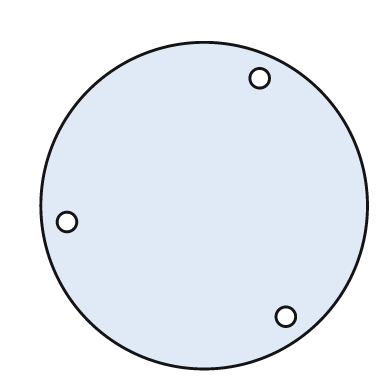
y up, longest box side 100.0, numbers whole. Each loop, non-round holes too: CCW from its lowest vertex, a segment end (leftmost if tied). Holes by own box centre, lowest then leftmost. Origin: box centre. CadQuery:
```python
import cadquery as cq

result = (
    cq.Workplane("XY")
    .moveTo(0.0, 0.0)
    .circle(50.0)
    .moveTo(25.0, -34.0)
    .circle(3.0)
    .moveTo(-42.0, -5.0)
    .circle(3.0)
    .moveTo(17.0, 39.0)
    .circle(3.0)
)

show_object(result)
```